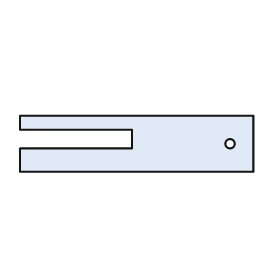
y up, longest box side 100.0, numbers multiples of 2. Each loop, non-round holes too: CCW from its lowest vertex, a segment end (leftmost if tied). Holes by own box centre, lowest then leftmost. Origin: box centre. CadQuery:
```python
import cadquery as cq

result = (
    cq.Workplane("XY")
    .moveTo(-50.0, -12.0)
    .lineTo(50.0, -12.0)
    .lineTo(50.0, 12.0)
    .lineTo(-50.0, 12.0)
    .lineTo(-50.0, 6.0)
    .lineTo(-2.0, 6.0)
    .lineTo(-2.0, -2.0)
    .lineTo(-50.0, -2.0)
    .close()
    .moveTo(40.0, 0.0)
    .circle(2.0)
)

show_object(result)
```